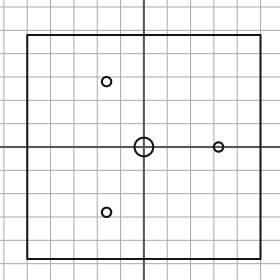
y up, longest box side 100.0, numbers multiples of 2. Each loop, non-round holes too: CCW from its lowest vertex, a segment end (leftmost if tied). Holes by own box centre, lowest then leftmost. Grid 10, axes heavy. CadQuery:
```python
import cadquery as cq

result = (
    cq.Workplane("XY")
    .moveTo(-50.0, -48.0)
    .lineTo(50.0, -48.0)
    .lineTo(50.0, 48.0)
    .lineTo(-50.0, 48.0)
    .close()
    .moveTo(-16.0, -28.0)
    .circle(2.0)
    .moveTo(0.0, 0.0)
    .circle(4.0)
    .moveTo(32.0, 0.0)
    .circle(2.0)
    .moveTo(-16.0, 28.0)
    .circle(2.0)
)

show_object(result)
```